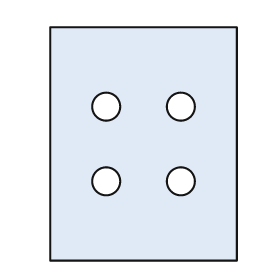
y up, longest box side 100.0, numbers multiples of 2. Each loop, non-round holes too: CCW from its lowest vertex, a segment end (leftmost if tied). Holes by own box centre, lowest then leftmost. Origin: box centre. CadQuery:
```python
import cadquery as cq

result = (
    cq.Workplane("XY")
    .moveTo(-40.0, -50.0)
    .lineTo(40.0, -50.0)
    .lineTo(40.0, 50.0)
    .lineTo(-40.0, 50.0)
    .close()
    .moveTo(-16.0, -16.0)
    .circle(6.0)
    .moveTo(16.0, -16.0)
    .circle(6.0)
    .moveTo(-16.0, 16.0)
    .circle(6.0)
    .moveTo(16.0, 16.0)
    .circle(6.0)
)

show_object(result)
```